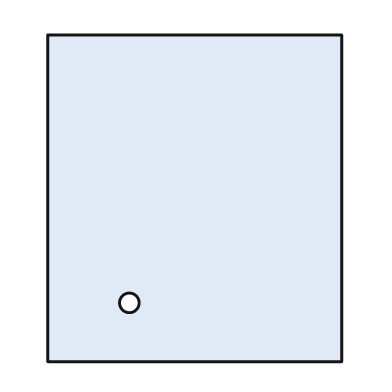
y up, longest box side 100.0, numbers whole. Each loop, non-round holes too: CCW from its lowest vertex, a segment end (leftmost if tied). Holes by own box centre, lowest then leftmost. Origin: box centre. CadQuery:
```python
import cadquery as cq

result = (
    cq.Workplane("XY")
    .moveTo(-45.0, -50.0)
    .lineTo(45.0, -50.0)
    .lineTo(45.0, 50.0)
    .lineTo(-45.0, 50.0)
    .close()
    .moveTo(-20.0, -32.0)
    .circle(3.0)
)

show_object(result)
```